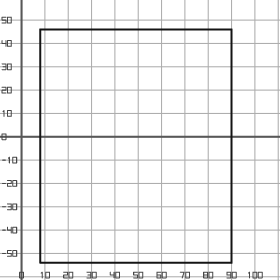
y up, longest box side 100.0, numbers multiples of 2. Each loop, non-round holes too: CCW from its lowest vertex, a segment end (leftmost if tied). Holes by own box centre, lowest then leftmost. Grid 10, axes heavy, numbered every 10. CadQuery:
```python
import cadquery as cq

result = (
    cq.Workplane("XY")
    .moveTo(8.0, -54.0)
    .lineTo(90.0, -54.0)
    .lineTo(90.0, 46.0)
    .lineTo(8.0, 46.0)
    .close()
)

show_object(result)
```